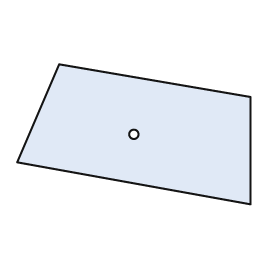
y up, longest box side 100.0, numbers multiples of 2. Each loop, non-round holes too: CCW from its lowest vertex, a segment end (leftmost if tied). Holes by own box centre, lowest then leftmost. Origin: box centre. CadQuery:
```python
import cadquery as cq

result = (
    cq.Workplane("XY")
    .moveTo(50.0, -30.0)
    .lineTo(50.0, 16.0)
    .lineTo(-32.0, 30.0)
    .lineTo(-50.0, -12.0)
    .close()
    .moveTo(0.0, 0.0)
    .circle(2.0)
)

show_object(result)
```